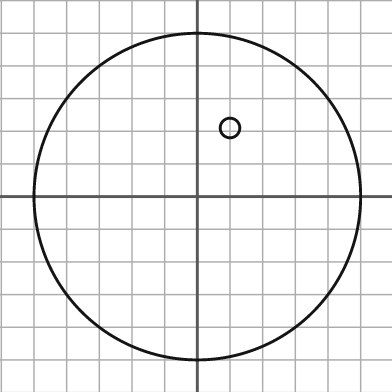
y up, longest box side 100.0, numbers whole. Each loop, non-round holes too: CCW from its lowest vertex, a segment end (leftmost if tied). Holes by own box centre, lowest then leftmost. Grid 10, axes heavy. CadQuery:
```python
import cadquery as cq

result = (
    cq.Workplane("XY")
    .moveTo(0.0, 0.0)
    .circle(50.0)
    .moveTo(10.0, 21.0)
    .circle(3.0)
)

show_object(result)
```